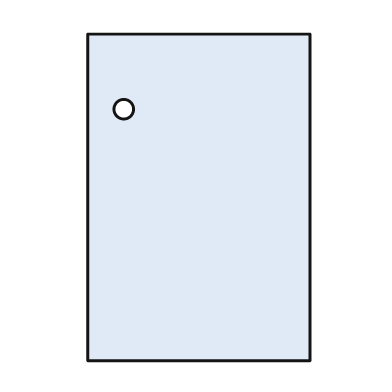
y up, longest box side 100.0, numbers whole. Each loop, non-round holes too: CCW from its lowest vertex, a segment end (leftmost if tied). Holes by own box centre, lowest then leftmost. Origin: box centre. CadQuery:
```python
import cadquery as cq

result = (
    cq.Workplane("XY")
    .moveTo(-34.0, -50.0)
    .lineTo(34.0, -50.0)
    .lineTo(34.0, 50.0)
    .lineTo(-34.0, 50.0)
    .close()
    .moveTo(-23.0, 27.0)
    .circle(3.0)
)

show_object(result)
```